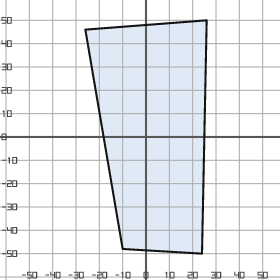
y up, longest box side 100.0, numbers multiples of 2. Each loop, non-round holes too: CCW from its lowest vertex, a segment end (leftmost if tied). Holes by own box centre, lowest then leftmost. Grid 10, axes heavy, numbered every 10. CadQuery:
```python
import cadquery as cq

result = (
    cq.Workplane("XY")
    .moveTo(24.0, -50.0)
    .lineTo(26.0, 50.0)
    .lineTo(-26.0, 46.0)
    .lineTo(-10.0, -48.0)
    .close()
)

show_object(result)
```